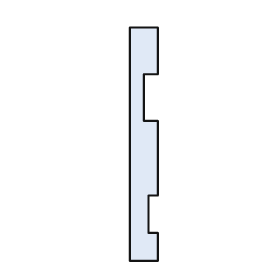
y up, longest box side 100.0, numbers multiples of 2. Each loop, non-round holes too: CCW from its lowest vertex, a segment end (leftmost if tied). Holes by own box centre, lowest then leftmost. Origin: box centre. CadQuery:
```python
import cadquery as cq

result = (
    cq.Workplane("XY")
    .moveTo(-6.0, -50.0)
    .lineTo(6.0, -50.0)
    .lineTo(6.0, -38.0)
    .lineTo(2.0, -38.0)
    .lineTo(2.0, -22.0)
    .lineTo(6.0, -22.0)
    .lineTo(6.0, 10.0)
    .lineTo(0.0, 10.0)
    .lineTo(0.0, 30.0)
    .lineTo(6.0, 30.0)
    .lineTo(6.0, 50.0)
    .lineTo(-6.0, 50.0)
    .close()
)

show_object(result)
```